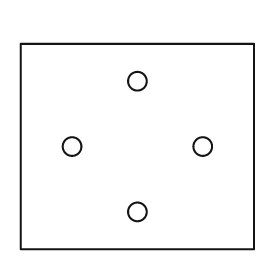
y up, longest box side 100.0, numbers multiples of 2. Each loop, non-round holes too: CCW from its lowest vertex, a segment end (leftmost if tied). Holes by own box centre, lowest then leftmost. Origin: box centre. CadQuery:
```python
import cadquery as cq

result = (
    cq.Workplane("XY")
    .moveTo(-50.0, -44.0)
    .lineTo(50.0, -44.0)
    .lineTo(50.0, 44.0)
    .lineTo(-50.0, 44.0)
    .close()
    .moveTo(0.0, -28.0)
    .circle(4.0)
    .moveTo(-28.0, 0.0)
    .circle(4.0)
    .moveTo(28.0, 0.0)
    .circle(4.0)
    .moveTo(0.0, 28.0)
    .circle(4.0)
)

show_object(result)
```